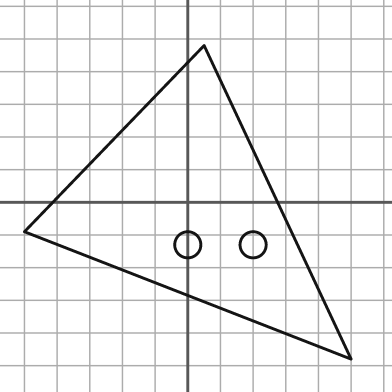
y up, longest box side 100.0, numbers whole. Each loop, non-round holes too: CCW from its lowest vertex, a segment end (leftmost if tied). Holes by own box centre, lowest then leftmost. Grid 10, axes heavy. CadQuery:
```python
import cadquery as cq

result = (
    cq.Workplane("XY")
    .moveTo(50.0, -48.0)
    .lineTo(5.0, 48.0)
    .lineTo(-50.0, -9.0)
    .close()
    .moveTo(0.0, -13.0)
    .circle(4.0)
    .moveTo(20.0, -13.0)
    .circle(4.0)
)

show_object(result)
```